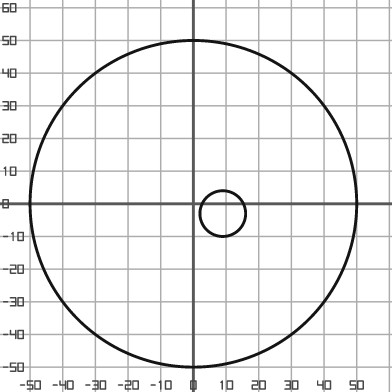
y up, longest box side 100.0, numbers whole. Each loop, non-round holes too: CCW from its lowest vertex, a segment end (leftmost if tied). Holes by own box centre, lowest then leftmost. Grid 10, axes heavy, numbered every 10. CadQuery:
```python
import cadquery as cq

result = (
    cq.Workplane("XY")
    .moveTo(0.0, 0.0)
    .circle(50.0)
    .moveTo(9.0, -3.0)
    .circle(7.0)
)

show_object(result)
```